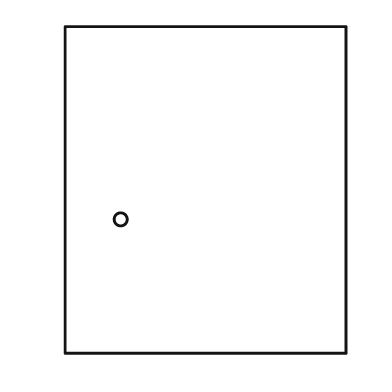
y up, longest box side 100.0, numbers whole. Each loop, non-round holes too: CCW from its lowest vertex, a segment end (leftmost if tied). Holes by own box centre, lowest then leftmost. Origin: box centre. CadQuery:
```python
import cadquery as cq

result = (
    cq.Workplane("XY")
    .moveTo(-43.0, -50.0)
    .lineTo(43.0, -50.0)
    .lineTo(43.0, 50.0)
    .lineTo(-43.0, 50.0)
    .close()
    .moveTo(-26.0, -9.0)
    .circle(2.0)
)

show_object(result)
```